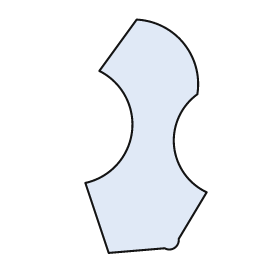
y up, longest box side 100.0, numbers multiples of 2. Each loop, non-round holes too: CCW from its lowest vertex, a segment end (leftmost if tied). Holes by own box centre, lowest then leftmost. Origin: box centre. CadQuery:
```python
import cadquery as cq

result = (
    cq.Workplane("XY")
    .moveTo(-16.0, -50.0)
    .lineTo(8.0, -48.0)
    .threePointArc((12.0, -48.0), (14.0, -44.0))
    .lineTo(26.0, -24.0)
    .threePointArc((12.0, -4.0), (22.0, 18.0))
    .threePointArc((16.0, 40.0), (-4.0, 50.0))
    .lineTo(-20.0, 28.0)
    .threePointArc((-6.0, 2.0), (-26.0, -20.0))
    .close()
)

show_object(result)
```